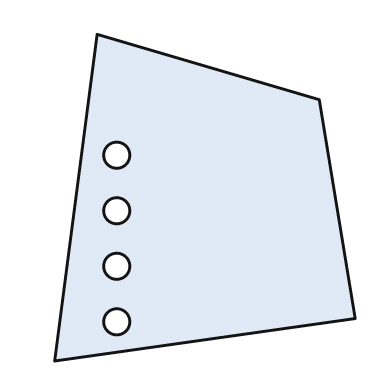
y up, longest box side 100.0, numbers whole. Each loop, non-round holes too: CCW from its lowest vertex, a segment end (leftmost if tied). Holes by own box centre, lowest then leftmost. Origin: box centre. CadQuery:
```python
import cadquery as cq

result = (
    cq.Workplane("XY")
    .moveTo(-46.0, -50.0)
    .lineTo(46.0, -37.0)
    .lineTo(35.0, 30.0)
    .lineTo(-33.0, 50.0)
    .close()
    .moveTo(-27.0, -38.0)
    .circle(4.0)
    .moveTo(-27.0, -21.0)
    .circle(4.0)
    .moveTo(-27.0, -4.0)
    .circle(4.0)
    .moveTo(-27.0, 13.0)
    .circle(4.0)
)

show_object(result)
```